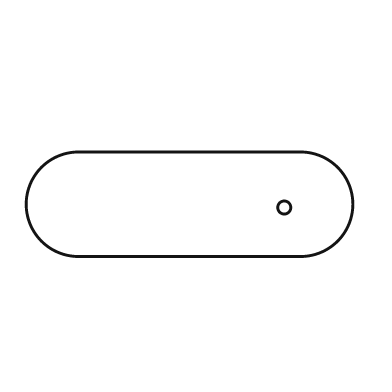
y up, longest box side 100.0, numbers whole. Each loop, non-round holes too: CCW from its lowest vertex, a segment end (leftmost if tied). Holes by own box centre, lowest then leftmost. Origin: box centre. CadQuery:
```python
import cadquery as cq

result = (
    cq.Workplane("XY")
    .moveTo(-34.0, -16.0)
    .lineTo(34.0, -16.0)
    .threePointArc((50.0, 0.0), (34.0, 16.0))
    .lineTo(-34.0, 16.0)
    .threePointArc((-50.0, 0.0), (-34.0, -16.0))
    .close()
    .moveTo(29.0, -1.0)
    .circle(2.0)
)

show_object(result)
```